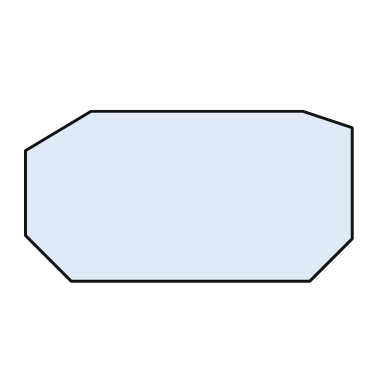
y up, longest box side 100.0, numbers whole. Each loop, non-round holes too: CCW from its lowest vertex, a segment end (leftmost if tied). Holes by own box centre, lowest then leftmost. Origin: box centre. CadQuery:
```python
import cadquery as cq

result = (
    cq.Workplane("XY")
    .moveTo(-36.0, -26.0)
    .lineTo(37.0, -26.0)
    .lineTo(50.0, -13.0)
    .lineTo(50.0, 21.0)
    .lineTo(35.0, 26.0)
    .lineTo(-30.0, 26.0)
    .lineTo(-50.0, 14.0)
    .lineTo(-50.0, -12.0)
    .close()
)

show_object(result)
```